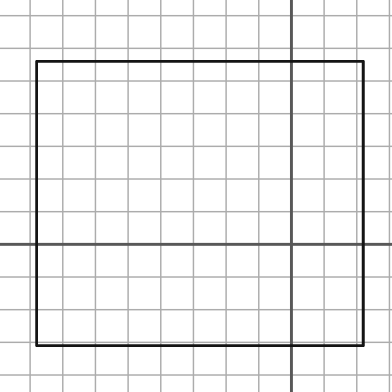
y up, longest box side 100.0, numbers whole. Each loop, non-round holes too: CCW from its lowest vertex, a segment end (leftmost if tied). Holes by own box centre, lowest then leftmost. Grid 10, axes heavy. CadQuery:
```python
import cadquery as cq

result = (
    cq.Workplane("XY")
    .moveTo(-78.0, -31.0)
    .lineTo(22.0, -31.0)
    .lineTo(22.0, 56.0)
    .lineTo(-78.0, 56.0)
    .close()
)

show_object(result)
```